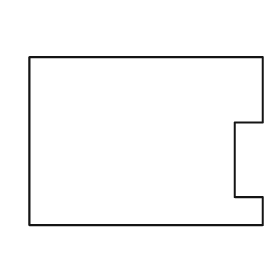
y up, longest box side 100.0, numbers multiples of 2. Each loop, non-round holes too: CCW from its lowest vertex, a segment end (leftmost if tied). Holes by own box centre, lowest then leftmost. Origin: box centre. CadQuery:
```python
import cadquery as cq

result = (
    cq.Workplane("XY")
    .moveTo(-50.0, -36.0)
    .lineTo(50.0, -36.0)
    .lineTo(50.0, -24.0)
    .lineTo(38.0, -24.0)
    .lineTo(38.0, 8.0)
    .lineTo(50.0, 8.0)
    .lineTo(50.0, 36.0)
    .lineTo(-50.0, 36.0)
    .close()
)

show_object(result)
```